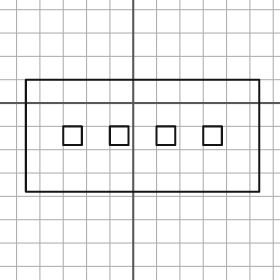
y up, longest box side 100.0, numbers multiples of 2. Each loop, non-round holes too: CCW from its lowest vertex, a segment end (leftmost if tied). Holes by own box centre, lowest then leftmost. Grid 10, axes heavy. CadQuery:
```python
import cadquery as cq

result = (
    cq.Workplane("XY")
    .moveTo(-46.0, -38.0)
    .lineTo(54.0, -38.0)
    .lineTo(54.0, 10.0)
    .lineTo(-46.0, 10.0)
    .close()
    .moveTo(-30.0, -18.0)
    .lineTo(-22.0, -18.0)
    .lineTo(-22.0, -10.0)
    .lineTo(-30.0, -10.0)
    .close()
    .moveTo(-10.0, -18.0)
    .lineTo(-2.0, -18.0)
    .lineTo(-2.0, -10.0)
    .lineTo(-10.0, -10.0)
    .close()
    .moveTo(10.0, -18.0)
    .lineTo(18.0, -18.0)
    .lineTo(18.0, -10.0)
    .lineTo(10.0, -10.0)
    .close()
    .moveTo(30.0, -18.0)
    .lineTo(38.0, -18.0)
    .lineTo(38.0, -10.0)
    .lineTo(30.0, -10.0)
    .close()
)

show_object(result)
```